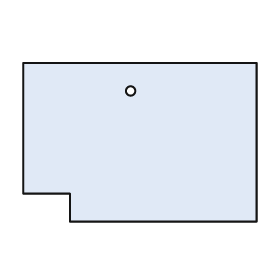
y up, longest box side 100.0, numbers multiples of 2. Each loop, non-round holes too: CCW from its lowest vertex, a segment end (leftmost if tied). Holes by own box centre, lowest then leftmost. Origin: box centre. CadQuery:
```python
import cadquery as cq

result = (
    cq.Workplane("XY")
    .moveTo(-30.0, -34.0)
    .lineTo(50.0, -34.0)
    .lineTo(50.0, 34.0)
    .lineTo(-50.0, 34.0)
    .lineTo(-50.0, -22.0)
    .lineTo(-30.0, -22.0)
    .close()
    .moveTo(-4.0, 22.0)
    .circle(2.0)
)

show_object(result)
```